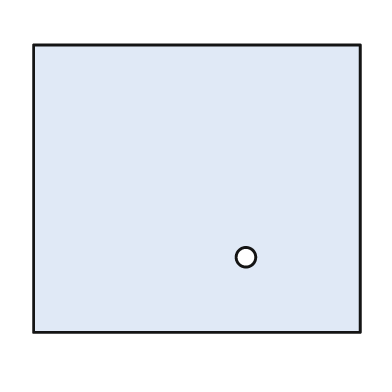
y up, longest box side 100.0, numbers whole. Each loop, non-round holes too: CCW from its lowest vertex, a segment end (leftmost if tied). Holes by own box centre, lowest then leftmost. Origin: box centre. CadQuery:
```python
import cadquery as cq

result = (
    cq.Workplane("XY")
    .moveTo(-50.0, -44.0)
    .lineTo(50.0, -44.0)
    .lineTo(50.0, 44.0)
    .lineTo(-50.0, 44.0)
    .close()
    .moveTo(15.0, -21.0)
    .circle(3.0)
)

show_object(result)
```